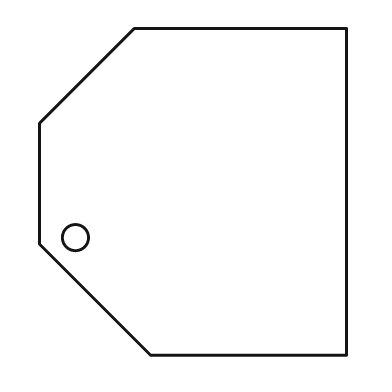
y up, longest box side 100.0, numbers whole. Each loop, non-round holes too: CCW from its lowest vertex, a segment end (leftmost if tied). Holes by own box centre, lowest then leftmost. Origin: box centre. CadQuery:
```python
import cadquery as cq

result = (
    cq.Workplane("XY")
    .moveTo(-13.0, -50.0)
    .lineTo(47.0, -50.0)
    .lineTo(47.0, 50.0)
    .lineTo(-18.0, 50.0)
    .lineTo(-47.0, 21.0)
    .lineTo(-47.0, -16.0)
    .close()
    .moveTo(-36.0, -14.0)
    .circle(4.0)
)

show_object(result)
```